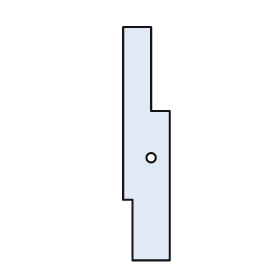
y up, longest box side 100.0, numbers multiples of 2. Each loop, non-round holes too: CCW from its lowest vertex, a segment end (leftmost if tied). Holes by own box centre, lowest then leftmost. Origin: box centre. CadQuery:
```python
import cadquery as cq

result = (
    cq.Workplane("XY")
    .moveTo(-6.0, -50.0)
    .lineTo(10.0, -50.0)
    .lineTo(10.0, 14.0)
    .lineTo(2.0, 14.0)
    .lineTo(2.0, 50.0)
    .lineTo(-10.0, 50.0)
    .lineTo(-10.0, -24.0)
    .lineTo(-6.0, -24.0)
    .close()
    .moveTo(2.0, -6.0)
    .circle(2.0)
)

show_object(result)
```